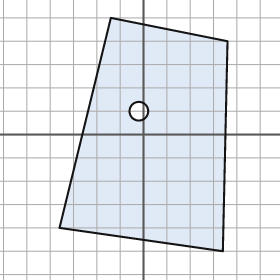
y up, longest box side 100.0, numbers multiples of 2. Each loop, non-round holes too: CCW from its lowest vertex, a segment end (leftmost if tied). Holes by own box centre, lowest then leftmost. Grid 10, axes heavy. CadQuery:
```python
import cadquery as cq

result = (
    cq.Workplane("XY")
    .moveTo(34.0, -50.0)
    .lineTo(36.0, 40.0)
    .lineTo(-14.0, 50.0)
    .lineTo(-36.0, -40.0)
    .close()
    .moveTo(-2.0, 10.0)
    .circle(4.0)
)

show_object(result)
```